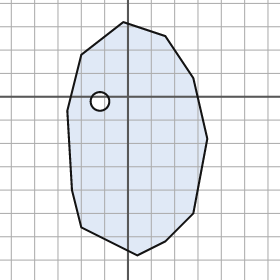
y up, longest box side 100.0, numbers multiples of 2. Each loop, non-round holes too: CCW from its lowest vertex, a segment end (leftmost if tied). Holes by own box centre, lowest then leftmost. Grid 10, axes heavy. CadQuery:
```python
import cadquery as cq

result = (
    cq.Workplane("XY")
    .moveTo(4.0, -68.0)
    .lineTo(16.0, -62.0)
    .lineTo(28.0, -50.0)
    .lineTo(34.0, -18.0)
    .lineTo(28.0, 8.0)
    .lineTo(16.0, 26.0)
    .lineTo(-2.0, 32.0)
    .lineTo(-20.0, 18.0)
    .lineTo(-26.0, -6.0)
    .lineTo(-24.0, -40.0)
    .lineTo(-20.0, -56.0)
    .close()
    .moveTo(-12.0, -2.0)
    .circle(4.0)
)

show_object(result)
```